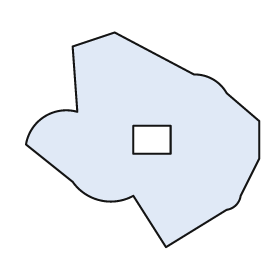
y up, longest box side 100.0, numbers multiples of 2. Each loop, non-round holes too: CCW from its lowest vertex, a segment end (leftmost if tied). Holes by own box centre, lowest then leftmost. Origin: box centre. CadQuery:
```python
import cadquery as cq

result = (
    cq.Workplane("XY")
    .moveTo(10.0, -46.0)
    .lineTo(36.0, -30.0)
    .threePointArc((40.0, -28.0), (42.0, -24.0))
    .lineTo(50.0, -8.0)
    .lineTo(50.0, 8.0)
    .lineTo(36.0, 20.0)
    .threePointArc((30.0, 26.0), (22.0, 28.0))
    .lineTo(-12.0, 46.0)
    .lineTo(-30.0, 40.0)
    .lineTo(-28.0, 12.0)
    .threePointArc((-42.0, 10.0), (-50.0, -2.0))
    .lineTo(-30.0, -18.0)
    .threePointArc((-18.0, -26.0), (-4.0, -24.0))
    .close()
    .moveTo(-4.0, -6.0)
    .lineTo(12.0, -6.0)
    .lineTo(12.0, 6.0)
    .lineTo(-4.0, 6.0)
    .close()
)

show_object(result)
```